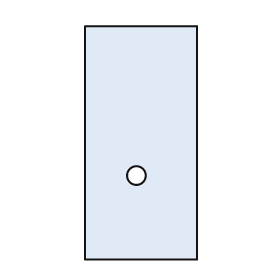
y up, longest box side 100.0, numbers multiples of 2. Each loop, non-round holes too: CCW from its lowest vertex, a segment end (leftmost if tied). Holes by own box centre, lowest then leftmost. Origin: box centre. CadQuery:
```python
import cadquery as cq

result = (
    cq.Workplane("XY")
    .moveTo(-24.0, -50.0)
    .lineTo(24.0, -50.0)
    .lineTo(24.0, 50.0)
    .lineTo(-24.0, 50.0)
    .close()
    .moveTo(-2.0, -14.0)
    .circle(4.0)
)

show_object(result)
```